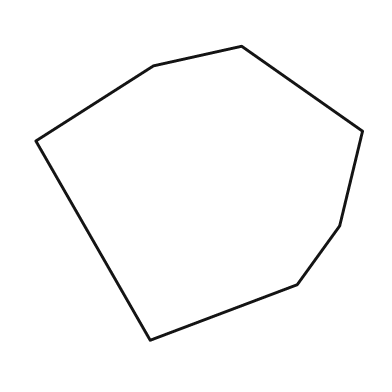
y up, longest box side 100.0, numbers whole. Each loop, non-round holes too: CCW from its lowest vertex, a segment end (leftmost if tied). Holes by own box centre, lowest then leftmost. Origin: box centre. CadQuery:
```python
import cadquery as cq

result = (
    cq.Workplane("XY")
    .moveTo(-15.0, -45.0)
    .lineTo(30.0, -28.0)
    .lineTo(43.0, -10.0)
    .lineTo(50.0, 19.0)
    .lineTo(13.0, 45.0)
    .lineTo(-14.0, 39.0)
    .lineTo(-50.0, 16.0)
    .close()
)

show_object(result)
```